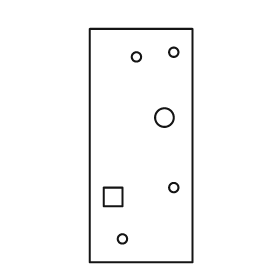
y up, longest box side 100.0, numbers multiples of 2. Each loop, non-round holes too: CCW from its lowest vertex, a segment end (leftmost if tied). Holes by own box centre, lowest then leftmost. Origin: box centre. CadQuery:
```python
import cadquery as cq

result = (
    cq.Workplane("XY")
    .moveTo(-22.0, -50.0)
    .lineTo(22.0, -50.0)
    .lineTo(22.0, 50.0)
    .lineTo(-22.0, 50.0)
    .close()
    .moveTo(-8.0, -40.0)
    .circle(2.0)
    .moveTo(-16.0, -26.0)
    .lineTo(-8.0, -26.0)
    .lineTo(-8.0, -18.0)
    .lineTo(-16.0, -18.0)
    .close()
    .moveTo(14.0, -18.0)
    .circle(2.0)
    .moveTo(10.0, 12.0)
    .circle(4.0)
    .moveTo(-2.0, 38.0)
    .circle(2.0)
    .moveTo(14.0, 40.0)
    .circle(2.0)
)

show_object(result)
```